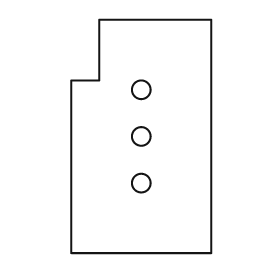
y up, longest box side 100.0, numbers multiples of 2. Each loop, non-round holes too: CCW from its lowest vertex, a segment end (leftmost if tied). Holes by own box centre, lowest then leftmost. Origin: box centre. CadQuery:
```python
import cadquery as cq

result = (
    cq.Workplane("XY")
    .moveTo(-30.0, -50.0)
    .lineTo(30.0, -50.0)
    .lineTo(30.0, 50.0)
    .lineTo(-18.0, 50.0)
    .lineTo(-18.0, 24.0)
    .lineTo(-30.0, 24.0)
    .close()
    .moveTo(0.0, -20.0)
    .circle(4.0)
    .moveTo(0.0, 0.0)
    .circle(4.0)
    .moveTo(0.0, 20.0)
    .circle(4.0)
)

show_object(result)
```